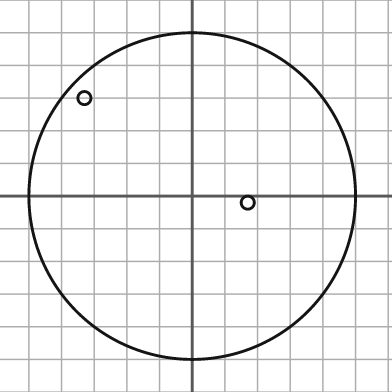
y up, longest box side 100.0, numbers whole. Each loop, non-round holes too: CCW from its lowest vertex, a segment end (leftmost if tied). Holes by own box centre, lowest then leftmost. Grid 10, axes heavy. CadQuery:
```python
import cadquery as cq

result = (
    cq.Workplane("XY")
    .moveTo(0.0, 0.0)
    .circle(50.0)
    .moveTo(17.0, -2.0)
    .circle(2.0)
    .moveTo(-33.0, 30.0)
    .circle(2.0)
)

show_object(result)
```